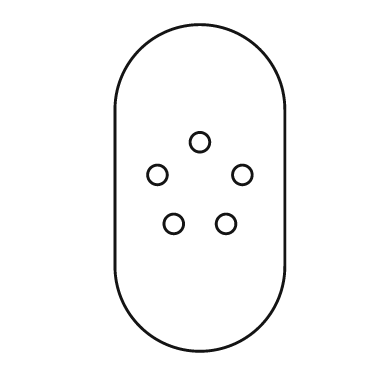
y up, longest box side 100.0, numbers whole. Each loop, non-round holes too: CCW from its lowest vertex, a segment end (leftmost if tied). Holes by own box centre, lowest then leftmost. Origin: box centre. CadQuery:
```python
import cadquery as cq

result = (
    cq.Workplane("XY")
    .moveTo(-26.0, -24.0)
    .threePointArc((0.0, -50.0), (26.0, -24.0))
    .lineTo(26.0, 24.0)
    .threePointArc((0.0, 50.0), (-26.0, 24.0))
    .close()
    .moveTo(-8.0, -11.0)
    .circle(3.0)
    .moveTo(8.0, -11.0)
    .circle(3.0)
    .moveTo(-13.0, 4.0)
    .circle(3.0)
    .moveTo(13.0, 4.0)
    .circle(3.0)
    .moveTo(0.0, 14.0)
    .circle(3.0)
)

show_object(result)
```